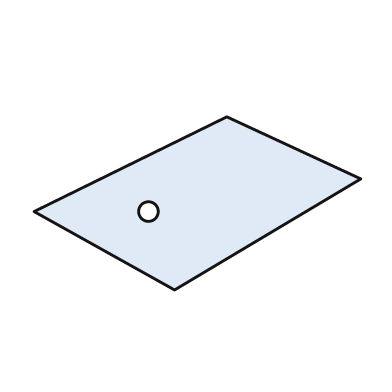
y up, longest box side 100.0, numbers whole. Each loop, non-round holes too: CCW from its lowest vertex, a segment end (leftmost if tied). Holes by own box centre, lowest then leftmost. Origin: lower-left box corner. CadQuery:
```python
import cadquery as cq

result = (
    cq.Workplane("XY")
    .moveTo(43.0, 0.0)
    .lineTo(100.0, 34.0)
    .lineTo(59.0, 53.0)
    .lineTo(0.0, 24.0)
    .close()
    .moveTo(35.0, 24.0)
    .circle(3.0)
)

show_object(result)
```